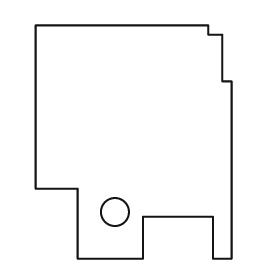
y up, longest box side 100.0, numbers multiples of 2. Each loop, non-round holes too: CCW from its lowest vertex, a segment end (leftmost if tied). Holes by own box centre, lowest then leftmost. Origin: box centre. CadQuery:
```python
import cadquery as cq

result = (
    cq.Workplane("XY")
    .moveTo(-24.0, -50.0)
    .lineTo(4.0, -50.0)
    .lineTo(4.0, -32.0)
    .lineTo(34.0, -32.0)
    .lineTo(34.0, -50.0)
    .lineTo(42.0, -50.0)
    .lineTo(42.0, 26.0)
    .lineTo(38.0, 26.0)
    .lineTo(38.0, 46.0)
    .lineTo(32.0, 46.0)
    .lineTo(32.0, 50.0)
    .lineTo(-42.0, 50.0)
    .lineTo(-42.0, -20.0)
    .lineTo(-24.0, -20.0)
    .close()
    .moveTo(-8.0, -30.0)
    .circle(6.0)
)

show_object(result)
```